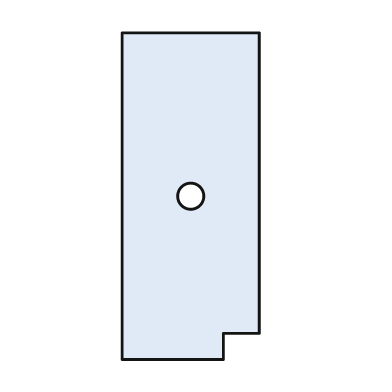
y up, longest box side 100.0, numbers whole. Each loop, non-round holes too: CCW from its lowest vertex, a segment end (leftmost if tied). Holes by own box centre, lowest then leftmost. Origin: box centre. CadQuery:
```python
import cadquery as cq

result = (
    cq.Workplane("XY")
    .moveTo(-21.0, -50.0)
    .lineTo(10.0, -50.0)
    .lineTo(10.0, -42.0)
    .lineTo(21.0, -42.0)
    .lineTo(21.0, 50.0)
    .lineTo(-21.0, 50.0)
    .close()
    .moveTo(0.0, 0.0)
    .circle(4.0)
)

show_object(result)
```